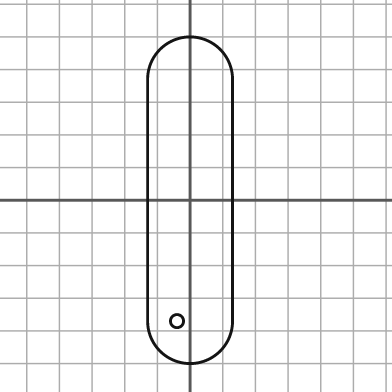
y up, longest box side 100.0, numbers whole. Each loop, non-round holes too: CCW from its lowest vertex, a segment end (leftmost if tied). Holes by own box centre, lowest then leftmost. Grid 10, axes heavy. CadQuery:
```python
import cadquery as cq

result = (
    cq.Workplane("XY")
    .moveTo(-13.0, -37.0)
    .threePointArc((0.0, -50.0), (13.0, -37.0))
    .lineTo(13.0, 37.0)
    .threePointArc((0.0, 50.0), (-13.0, 37.0))
    .close()
    .moveTo(-4.0, -37.0)
    .circle(2.0)
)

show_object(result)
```